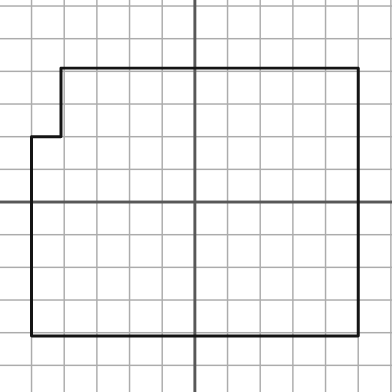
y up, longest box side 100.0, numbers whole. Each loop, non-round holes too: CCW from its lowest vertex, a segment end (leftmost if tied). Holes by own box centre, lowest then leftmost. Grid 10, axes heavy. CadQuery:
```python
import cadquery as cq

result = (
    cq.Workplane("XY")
    .moveTo(-50.0, -41.0)
    .lineTo(50.0, -41.0)
    .lineTo(50.0, 41.0)
    .lineTo(-41.0, 41.0)
    .lineTo(-41.0, 20.0)
    .lineTo(-50.0, 20.0)
    .close()
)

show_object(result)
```